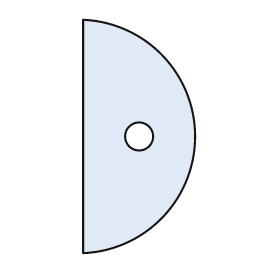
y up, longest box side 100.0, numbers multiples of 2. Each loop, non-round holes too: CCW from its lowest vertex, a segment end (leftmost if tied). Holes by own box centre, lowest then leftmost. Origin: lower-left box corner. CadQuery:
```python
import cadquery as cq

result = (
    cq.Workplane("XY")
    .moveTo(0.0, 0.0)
    .threePointArc((48.0, 50.0), (0.0, 100.0))
    .close()
    .moveTo(24.0, 50.0)
    .circle(6.0)
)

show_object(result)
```